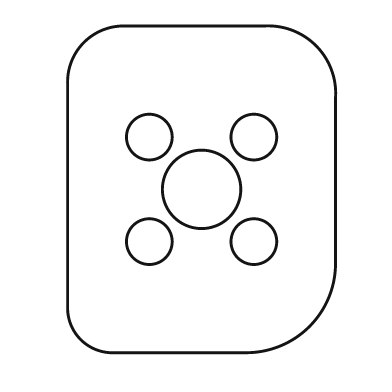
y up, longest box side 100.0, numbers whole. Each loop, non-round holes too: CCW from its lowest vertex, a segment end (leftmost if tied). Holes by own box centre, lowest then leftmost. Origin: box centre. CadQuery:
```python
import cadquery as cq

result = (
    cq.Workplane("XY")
    .moveTo(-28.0, -50.0)
    .lineTo(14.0, -50.0)
    .threePointArc((33.0, -42.0), (41.0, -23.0))
    .lineTo(41.0, 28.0)
    .threePointArc((35.0, 44.0), (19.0, 50.0))
    .lineTo(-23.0, 50.0)
    .threePointArc((-36.0, 45.0), (-41.0, 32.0))
    .lineTo(-41.0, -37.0)
    .threePointArc((-37.0, -46.0), (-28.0, -50.0))
    .close()
    .moveTo(-16.0, -16.0)
    .circle(7.0)
    .moveTo(16.0, -16.0)
    .circle(7.0)
    .moveTo(0.0, 0.0)
    .circle(12.0)
    .moveTo(-16.0, 16.0)
    .circle(7.0)
    .moveTo(16.0, 16.0)
    .circle(7.0)
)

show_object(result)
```